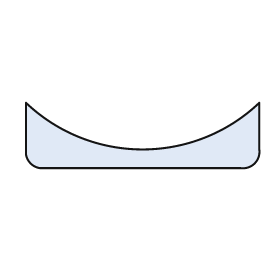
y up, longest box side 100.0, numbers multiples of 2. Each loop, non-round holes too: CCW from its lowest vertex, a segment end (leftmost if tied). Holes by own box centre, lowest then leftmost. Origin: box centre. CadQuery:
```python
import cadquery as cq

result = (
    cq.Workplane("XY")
    .moveTo(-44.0, -14.0)
    .lineTo(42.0, -14.0)
    .threePointArc((48.0, -12.0), (50.0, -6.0))
    .lineTo(50.0, 14.0)
    .threePointArc((0.0, -6.0), (-50.0, 14.0))
    .lineTo(-50.0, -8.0)
    .threePointArc((-48.0, -12.0), (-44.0, -14.0))
    .close()
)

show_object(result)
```